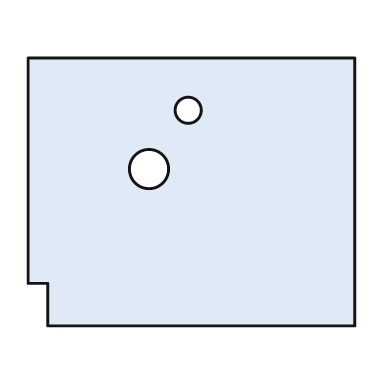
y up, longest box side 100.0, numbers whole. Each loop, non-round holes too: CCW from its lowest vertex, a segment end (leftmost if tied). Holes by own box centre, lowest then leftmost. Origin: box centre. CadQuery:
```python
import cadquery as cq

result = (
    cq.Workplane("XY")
    .moveTo(-44.0, -41.0)
    .lineTo(50.0, -41.0)
    .lineTo(50.0, 41.0)
    .lineTo(-50.0, 41.0)
    .lineTo(-50.0, -28.0)
    .lineTo(-44.0, -28.0)
    .close()
    .moveTo(-13.0, 7.0)
    .circle(6.0)
    .moveTo(-1.0, 25.0)
    .circle(4.0)
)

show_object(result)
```